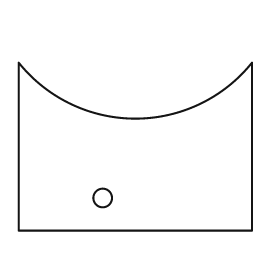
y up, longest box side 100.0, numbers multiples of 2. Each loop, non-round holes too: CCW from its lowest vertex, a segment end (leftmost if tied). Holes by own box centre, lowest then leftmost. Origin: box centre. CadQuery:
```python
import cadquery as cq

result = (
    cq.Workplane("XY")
    .moveTo(-50.0, -36.0)
    .lineTo(50.0, -36.0)
    .lineTo(50.0, 36.0)
    .threePointArc((0.0, 12.0), (-50.0, 36.0))
    .close()
    .moveTo(-14.0, -22.0)
    .circle(4.0)
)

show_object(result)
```